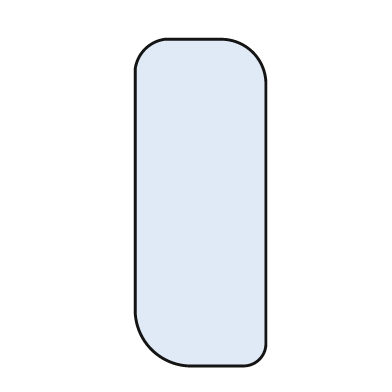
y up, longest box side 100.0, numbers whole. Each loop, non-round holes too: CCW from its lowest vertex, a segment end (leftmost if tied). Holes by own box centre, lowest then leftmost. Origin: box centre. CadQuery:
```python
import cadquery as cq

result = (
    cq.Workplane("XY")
    .moveTo(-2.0, -50.0)
    .lineTo(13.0, -50.0)
    .threePointArc((18.0, -48.0), (20.0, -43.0))
    .lineTo(20.0, 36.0)
    .threePointArc((16.0, 46.0), (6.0, 50.0))
    .lineTo(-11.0, 50.0)
    .threePointArc((-17.0, 47.0), (-20.0, 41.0))
    .lineTo(-20.0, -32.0)
    .threePointArc((-15.0, -45.0), (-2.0, -50.0))
    .close()
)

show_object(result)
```